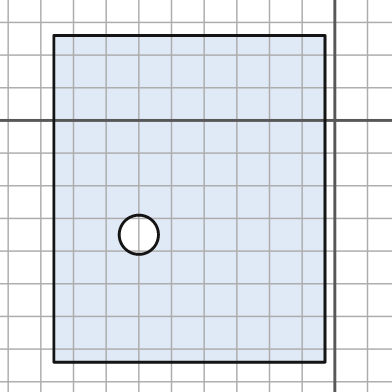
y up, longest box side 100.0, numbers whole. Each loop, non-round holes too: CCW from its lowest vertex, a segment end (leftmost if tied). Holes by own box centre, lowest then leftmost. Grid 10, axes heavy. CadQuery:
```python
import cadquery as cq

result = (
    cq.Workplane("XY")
    .moveTo(-86.0, -74.0)
    .lineTo(-3.0, -74.0)
    .lineTo(-3.0, 26.0)
    .lineTo(-86.0, 26.0)
    .close()
    .moveTo(-60.0, -35.0)
    .circle(6.0)
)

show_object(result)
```